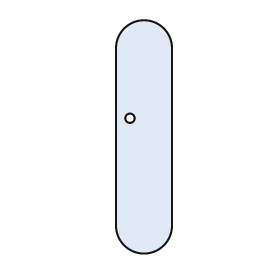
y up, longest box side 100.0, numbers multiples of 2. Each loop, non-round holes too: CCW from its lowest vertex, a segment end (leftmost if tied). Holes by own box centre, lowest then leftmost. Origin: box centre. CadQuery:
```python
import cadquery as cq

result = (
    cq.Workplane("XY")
    .moveTo(-12.0, -38.0)
    .threePointArc((0.0, -50.0), (12.0, -38.0))
    .lineTo(12.0, 38.0)
    .threePointArc((0.0, 50.0), (-12.0, 38.0))
    .close()
    .moveTo(-6.0, 8.0)
    .circle(2.0)
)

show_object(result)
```